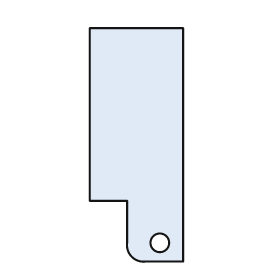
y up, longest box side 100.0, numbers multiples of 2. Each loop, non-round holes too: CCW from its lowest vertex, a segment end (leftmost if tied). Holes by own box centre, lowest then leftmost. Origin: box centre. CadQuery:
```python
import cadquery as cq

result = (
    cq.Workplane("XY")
    .moveTo(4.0, -50.0)
    .lineTo(20.0, -50.0)
    .lineTo(20.0, 50.0)
    .lineTo(-20.0, 50.0)
    .lineTo(-20.0, -24.0)
    .lineTo(-4.0, -24.0)
    .lineTo(-4.0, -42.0)
    .threePointArc((-2.0, -48.0), (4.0, -50.0))
    .close()
    .moveTo(10.0, -42.0)
    .circle(4.0)
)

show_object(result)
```